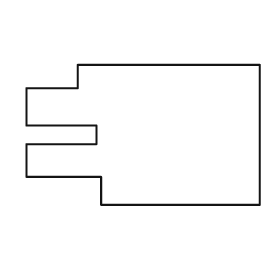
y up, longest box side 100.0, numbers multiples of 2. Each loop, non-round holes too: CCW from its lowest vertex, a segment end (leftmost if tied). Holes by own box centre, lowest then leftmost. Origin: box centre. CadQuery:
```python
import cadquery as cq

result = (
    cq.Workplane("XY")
    .moveTo(-18.0, -30.0)
    .lineTo(50.0, -30.0)
    .lineTo(50.0, 30.0)
    .lineTo(-28.0, 30.0)
    .lineTo(-28.0, 20.0)
    .lineTo(-50.0, 20.0)
    .lineTo(-50.0, 4.0)
    .lineTo(-20.0, 4.0)
    .lineTo(-20.0, -4.0)
    .lineTo(-50.0, -4.0)
    .lineTo(-50.0, -18.0)
    .lineTo(-18.0, -18.0)
    .close()
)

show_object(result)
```